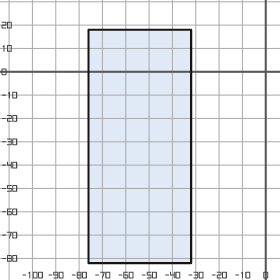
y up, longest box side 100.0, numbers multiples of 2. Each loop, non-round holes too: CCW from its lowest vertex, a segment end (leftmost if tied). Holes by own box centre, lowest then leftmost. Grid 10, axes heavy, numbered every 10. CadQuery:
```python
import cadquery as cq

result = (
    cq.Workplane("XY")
    .moveTo(-76.0, -82.0)
    .lineTo(-32.0, -82.0)
    .lineTo(-32.0, 18.0)
    .lineTo(-76.0, 18.0)
    .close()
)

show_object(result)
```